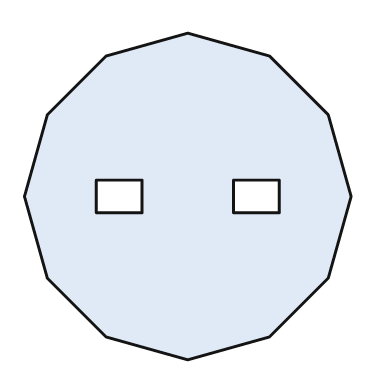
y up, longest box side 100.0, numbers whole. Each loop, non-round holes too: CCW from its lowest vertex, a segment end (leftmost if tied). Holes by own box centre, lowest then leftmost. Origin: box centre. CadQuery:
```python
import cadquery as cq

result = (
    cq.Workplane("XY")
    .moveTo(0.0, -50.0)
    .lineTo(25.0, -43.0)
    .lineTo(43.0, -25.0)
    .lineTo(50.0, 0.0)
    .lineTo(43.0, 25.0)
    .lineTo(25.0, 43.0)
    .lineTo(0.0, 50.0)
    .lineTo(-25.0, 43.0)
    .lineTo(-43.0, 25.0)
    .lineTo(-50.0, 0.0)
    .lineTo(-43.0, -25.0)
    .lineTo(-25.0, -43.0)
    .close()
    .moveTo(-28.0, -5.0)
    .lineTo(-14.0, -5.0)
    .lineTo(-14.0, 5.0)
    .lineTo(-28.0, 5.0)
    .close()
    .moveTo(14.0, -5.0)
    .lineTo(28.0, -5.0)
    .lineTo(28.0, 5.0)
    .lineTo(14.0, 5.0)
    .close()
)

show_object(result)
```